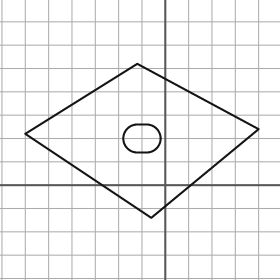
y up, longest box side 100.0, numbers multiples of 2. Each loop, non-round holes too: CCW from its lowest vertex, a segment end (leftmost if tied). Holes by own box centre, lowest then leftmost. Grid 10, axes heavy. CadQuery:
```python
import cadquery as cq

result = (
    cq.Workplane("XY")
    .moveTo(-6.0, -14.0)
    .lineTo(40.0, 24.0)
    .lineTo(-12.0, 52.0)
    .lineTo(-60.0, 22.0)
    .close()
    .moveTo(-12.0, 14.0)
    .lineTo(-8.0, 14.0)
    .threePointArc((-2.0, 20.0), (-8.0, 26.0))
    .lineTo(-12.0, 26.0)
    .threePointArc((-18.0, 20.0), (-12.0, 14.0))
    .close()
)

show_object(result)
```